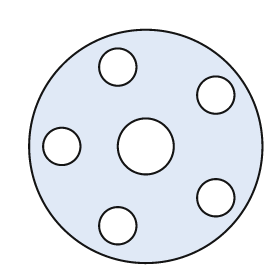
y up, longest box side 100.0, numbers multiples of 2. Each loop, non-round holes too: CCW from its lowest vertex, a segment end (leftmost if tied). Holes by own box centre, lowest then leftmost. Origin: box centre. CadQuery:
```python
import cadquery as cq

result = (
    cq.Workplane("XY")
    .moveTo(0.0, 0.0)
    .circle(50.0)
    .moveTo(-12.0, -34.0)
    .circle(8.0)
    .moveTo(30.0, -22.0)
    .circle(8.0)
    .moveTo(-36.0, 0.0)
    .circle(8.0)
    .moveTo(0.0, 0.0)
    .circle(12.0)
    .moveTo(30.0, 22.0)
    .circle(8.0)
    .moveTo(-12.0, 34.0)
    .circle(8.0)
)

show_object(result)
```